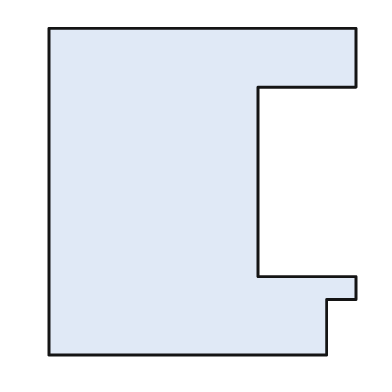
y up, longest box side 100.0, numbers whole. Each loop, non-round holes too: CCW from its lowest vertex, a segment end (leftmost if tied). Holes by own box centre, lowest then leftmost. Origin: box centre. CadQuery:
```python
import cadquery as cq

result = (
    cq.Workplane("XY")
    .moveTo(-47.0, -50.0)
    .lineTo(38.0, -50.0)
    .lineTo(38.0, -33.0)
    .lineTo(47.0, -33.0)
    .lineTo(47.0, -26.0)
    .lineTo(17.0, -26.0)
    .lineTo(17.0, 32.0)
    .lineTo(47.0, 32.0)
    .lineTo(47.0, 50.0)
    .lineTo(-47.0, 50.0)
    .close()
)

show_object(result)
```